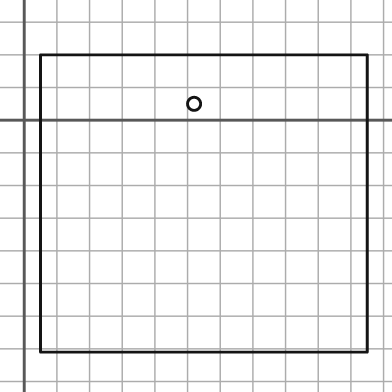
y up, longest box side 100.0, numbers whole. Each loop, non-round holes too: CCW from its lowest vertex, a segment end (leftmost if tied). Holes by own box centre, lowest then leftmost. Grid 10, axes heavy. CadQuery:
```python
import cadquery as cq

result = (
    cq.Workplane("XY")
    .moveTo(5.0, -71.0)
    .lineTo(105.0, -71.0)
    .lineTo(105.0, 20.0)
    .lineTo(5.0, 20.0)
    .close()
    .moveTo(52.0, 5.0)
    .circle(2.0)
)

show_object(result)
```